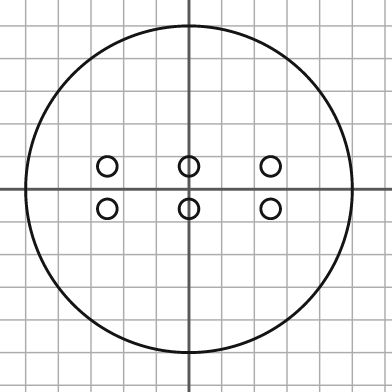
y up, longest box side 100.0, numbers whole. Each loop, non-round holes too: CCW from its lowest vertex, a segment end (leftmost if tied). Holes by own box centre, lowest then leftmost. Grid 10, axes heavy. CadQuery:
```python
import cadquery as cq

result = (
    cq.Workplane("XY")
    .moveTo(0.0, 0.0)
    .circle(50.0)
    .moveTo(-25.0, -6.0)
    .circle(3.0)
    .moveTo(0.0, -6.0)
    .circle(3.0)
    .moveTo(25.0, -6.0)
    .circle(3.0)
    .moveTo(-25.0, 7.0)
    .circle(3.0)
    .moveTo(0.0, 7.0)
    .circle(3.0)
    .moveTo(25.0, 7.0)
    .circle(3.0)
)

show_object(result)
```